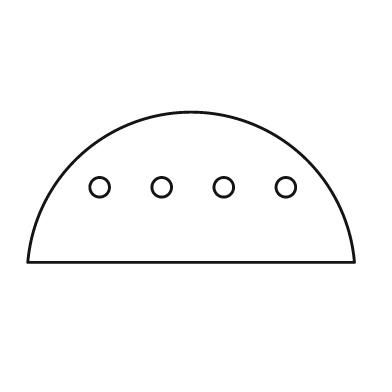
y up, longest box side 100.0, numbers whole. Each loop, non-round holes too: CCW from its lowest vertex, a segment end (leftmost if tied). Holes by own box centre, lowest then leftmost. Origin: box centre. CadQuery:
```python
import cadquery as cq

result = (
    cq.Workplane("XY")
    .moveTo(-50.0, -23.0)
    .lineTo(50.0, -23.0)
    .threePointArc((0.0, 23.0), (-50.0, -23.0))
    .close()
    .moveTo(-28.0, 0.0)
    .circle(3.0)
    .moveTo(-9.0, 0.0)
    .circle(3.0)
    .moveTo(10.0, 0.0)
    .circle(3.0)
    .moveTo(29.0, 0.0)
    .circle(3.0)
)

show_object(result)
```